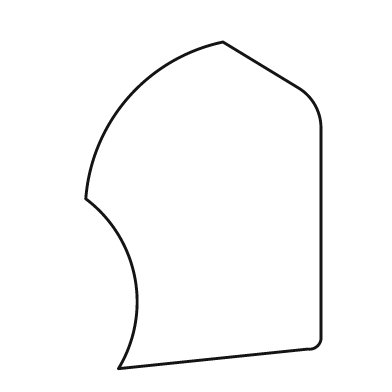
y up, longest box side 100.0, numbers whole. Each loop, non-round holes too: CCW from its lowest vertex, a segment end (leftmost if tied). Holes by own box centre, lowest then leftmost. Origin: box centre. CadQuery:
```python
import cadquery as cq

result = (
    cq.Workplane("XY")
    .moveTo(-26.0, -50.0)
    .lineTo(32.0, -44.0)
    .threePointArc((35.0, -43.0), (36.0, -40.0))
    .lineTo(36.0, 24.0)
    .threePointArc((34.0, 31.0), (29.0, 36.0))
    .lineTo(6.0, 50.0)
    .threePointArc((-23.0, 33.0), (-36.0, 2.0))
    .threePointArc((-21.0, -22.0), (-26.0, -50.0))
    .close()
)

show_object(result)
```